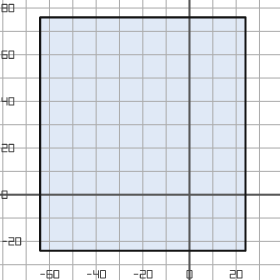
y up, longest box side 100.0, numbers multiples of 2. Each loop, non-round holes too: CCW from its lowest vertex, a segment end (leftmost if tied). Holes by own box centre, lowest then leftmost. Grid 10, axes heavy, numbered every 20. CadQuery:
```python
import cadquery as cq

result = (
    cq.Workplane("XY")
    .moveTo(-64.0, -24.0)
    .lineTo(24.0, -24.0)
    .lineTo(24.0, 76.0)
    .lineTo(-64.0, 76.0)
    .close()
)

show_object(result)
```